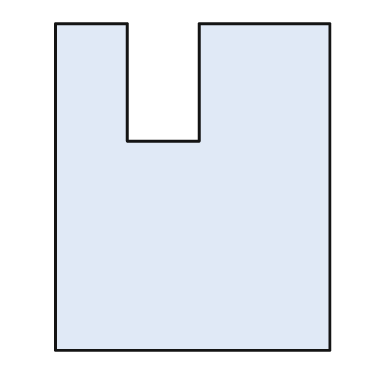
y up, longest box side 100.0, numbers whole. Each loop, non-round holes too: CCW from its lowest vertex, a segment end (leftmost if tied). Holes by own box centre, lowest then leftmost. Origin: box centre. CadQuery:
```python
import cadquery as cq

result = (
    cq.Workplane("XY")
    .moveTo(-42.0, -50.0)
    .lineTo(42.0, -50.0)
    .lineTo(42.0, 50.0)
    .lineTo(2.0, 50.0)
    .lineTo(2.0, 14.0)
    .lineTo(-20.0, 14.0)
    .lineTo(-20.0, 50.0)
    .lineTo(-42.0, 50.0)
    .close()
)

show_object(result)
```